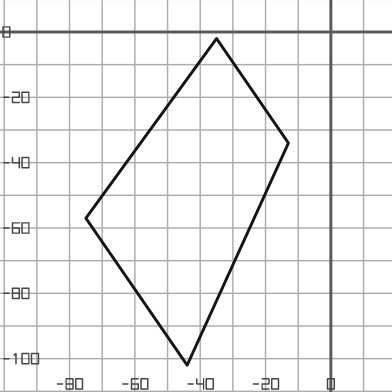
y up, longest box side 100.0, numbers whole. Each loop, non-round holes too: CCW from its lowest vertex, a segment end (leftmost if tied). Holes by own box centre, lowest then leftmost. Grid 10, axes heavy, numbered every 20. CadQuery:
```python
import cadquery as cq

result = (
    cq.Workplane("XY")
    .moveTo(-44.0, -102.0)
    .lineTo(-13.0, -34.0)
    .lineTo(-35.0, -2.0)
    .lineTo(-75.0, -57.0)
    .close()
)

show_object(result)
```